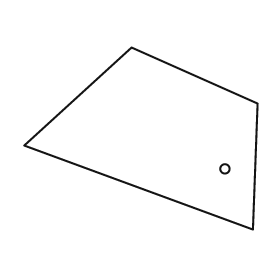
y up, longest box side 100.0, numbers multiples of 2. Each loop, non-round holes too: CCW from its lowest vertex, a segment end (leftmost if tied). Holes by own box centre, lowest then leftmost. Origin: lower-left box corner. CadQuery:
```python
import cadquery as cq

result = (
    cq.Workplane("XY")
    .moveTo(98.0, 0.0)
    .lineTo(100.0, 54.0)
    .lineTo(46.0, 78.0)
    .lineTo(0.0, 36.0)
    .close()
    .moveTo(86.0, 26.0)
    .circle(2.0)
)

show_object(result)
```